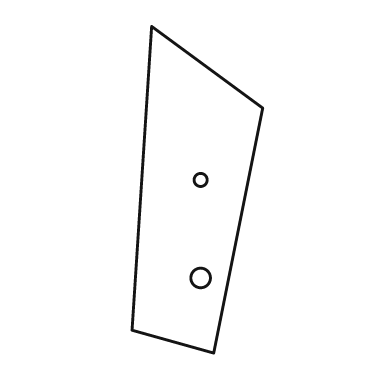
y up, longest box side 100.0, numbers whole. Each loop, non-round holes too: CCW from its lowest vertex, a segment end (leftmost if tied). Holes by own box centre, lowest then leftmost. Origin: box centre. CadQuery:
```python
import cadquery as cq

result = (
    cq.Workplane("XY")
    .moveTo(5.0, -50.0)
    .lineTo(20.0, 25.0)
    .lineTo(-14.0, 50.0)
    .lineTo(-20.0, -43.0)
    .close()
    .moveTo(1.0, -27.0)
    .circle(3.0)
    .moveTo(1.0, 3.0)
    .circle(2.0)
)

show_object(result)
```